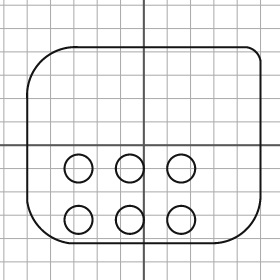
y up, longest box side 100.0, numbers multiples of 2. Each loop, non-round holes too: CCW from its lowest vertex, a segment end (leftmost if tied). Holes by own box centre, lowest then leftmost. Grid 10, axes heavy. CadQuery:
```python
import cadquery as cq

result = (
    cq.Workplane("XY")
    .moveTo(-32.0, -42.0)
    .lineTo(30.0, -42.0)
    .threePointArc((44.0, -36.0), (50.0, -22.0))
    .lineTo(50.0, 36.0)
    .threePointArc((48.0, 40.0), (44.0, 42.0))
    .lineTo(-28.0, 42.0)
    .threePointArc((-44.0, 36.0), (-50.0, 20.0))
    .lineTo(-50.0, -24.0)
    .threePointArc((-44.0, -36.0), (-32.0, -42.0))
    .close()
    .moveTo(-28.0, -32.0)
    .circle(6.0)
    .moveTo(-6.0, -32.0)
    .circle(6.0)
    .moveTo(16.0, -32.0)
    .circle(6.0)
    .moveTo(-28.0, -10.0)
    .circle(6.0)
    .moveTo(-6.0, -10.0)
    .circle(6.0)
    .moveTo(16.0, -10.0)
    .circle(6.0)
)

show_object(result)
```